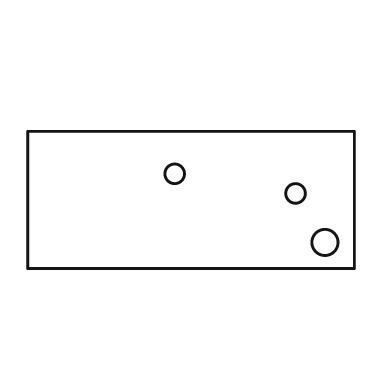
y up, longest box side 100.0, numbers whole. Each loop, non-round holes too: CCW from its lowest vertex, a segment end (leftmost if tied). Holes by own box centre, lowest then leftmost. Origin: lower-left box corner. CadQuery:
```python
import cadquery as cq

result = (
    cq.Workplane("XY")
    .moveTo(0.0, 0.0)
    .lineTo(100.0, 0.0)
    .lineTo(100.0, 42.0)
    .lineTo(0.0, 42.0)
    .close()
    .moveTo(91.0, 8.0)
    .circle(4.0)
    .moveTo(82.0, 23.0)
    .circle(3.0)
    .moveTo(45.0, 29.0)
    .circle(3.0)
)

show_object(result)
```